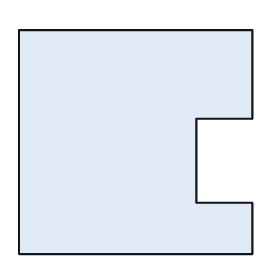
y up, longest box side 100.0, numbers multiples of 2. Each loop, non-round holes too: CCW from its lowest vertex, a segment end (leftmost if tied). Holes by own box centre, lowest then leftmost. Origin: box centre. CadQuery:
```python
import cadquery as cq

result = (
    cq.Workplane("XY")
    .moveTo(-50.0, -48.0)
    .lineTo(50.0, -48.0)
    .lineTo(50.0, -26.0)
    .lineTo(26.0, -26.0)
    .lineTo(26.0, 10.0)
    .lineTo(50.0, 10.0)
    .lineTo(50.0, 48.0)
    .lineTo(-50.0, 48.0)
    .close()
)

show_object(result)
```